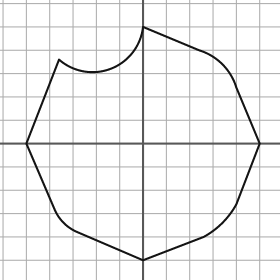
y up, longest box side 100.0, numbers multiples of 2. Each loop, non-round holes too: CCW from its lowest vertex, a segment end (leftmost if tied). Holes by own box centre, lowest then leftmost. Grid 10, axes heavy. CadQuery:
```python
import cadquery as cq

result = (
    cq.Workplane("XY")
    .moveTo(0.0, -50.0)
    .lineTo(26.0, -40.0)
    .threePointArc((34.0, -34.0), (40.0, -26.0))
    .lineTo(50.0, 0.0)
    .lineTo(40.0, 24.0)
    .threePointArc((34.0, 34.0), (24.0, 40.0))
    .lineTo(0.0, 50.0)
    .threePointArc((-14.0, 32.0), (-36.0, 36.0))
    .lineTo(-50.0, 0.0)
    .lineTo(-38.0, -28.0)
    .threePointArc((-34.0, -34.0), (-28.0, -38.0))
    .close()
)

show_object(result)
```